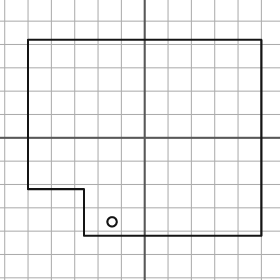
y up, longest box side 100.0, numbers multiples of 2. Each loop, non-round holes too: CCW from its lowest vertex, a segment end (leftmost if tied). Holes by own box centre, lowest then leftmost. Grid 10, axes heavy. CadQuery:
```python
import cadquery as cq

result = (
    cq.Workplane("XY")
    .moveTo(-26.0, -42.0)
    .lineTo(50.0, -42.0)
    .lineTo(50.0, 42.0)
    .lineTo(-50.0, 42.0)
    .lineTo(-50.0, -22.0)
    .lineTo(-26.0, -22.0)
    .close()
    .moveTo(-14.0, -36.0)
    .circle(2.0)
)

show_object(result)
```